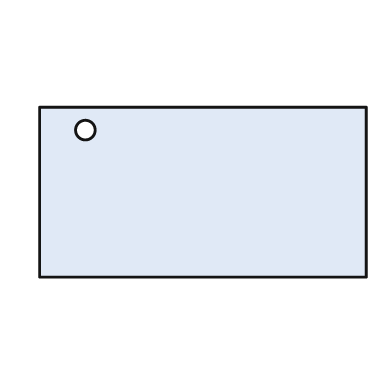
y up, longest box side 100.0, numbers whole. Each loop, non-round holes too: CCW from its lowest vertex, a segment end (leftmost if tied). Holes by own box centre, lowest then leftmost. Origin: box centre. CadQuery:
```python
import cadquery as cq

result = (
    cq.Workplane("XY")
    .moveTo(-50.0, -26.0)
    .lineTo(50.0, -26.0)
    .lineTo(50.0, 26.0)
    .lineTo(-50.0, 26.0)
    .close()
    .moveTo(-36.0, 19.0)
    .circle(3.0)
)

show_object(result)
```